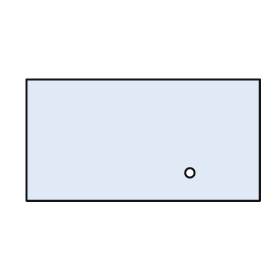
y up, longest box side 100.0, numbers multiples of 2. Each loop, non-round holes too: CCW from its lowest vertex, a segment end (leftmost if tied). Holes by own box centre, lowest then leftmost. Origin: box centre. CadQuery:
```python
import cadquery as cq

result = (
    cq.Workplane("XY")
    .moveTo(-50.0, -26.0)
    .lineTo(50.0, -26.0)
    .lineTo(50.0, 26.0)
    .lineTo(-50.0, 26.0)
    .close()
    .moveTo(20.0, -14.0)
    .circle(2.0)
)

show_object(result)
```